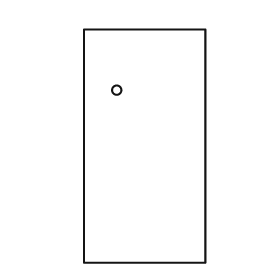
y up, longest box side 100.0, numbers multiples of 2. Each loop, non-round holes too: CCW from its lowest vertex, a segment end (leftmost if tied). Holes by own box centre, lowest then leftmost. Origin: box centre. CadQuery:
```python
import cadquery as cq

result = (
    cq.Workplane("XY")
    .moveTo(-26.0, -50.0)
    .lineTo(26.0, -50.0)
    .lineTo(26.0, 50.0)
    .lineTo(-26.0, 50.0)
    .close()
    .moveTo(-12.0, 24.0)
    .circle(2.0)
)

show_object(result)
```